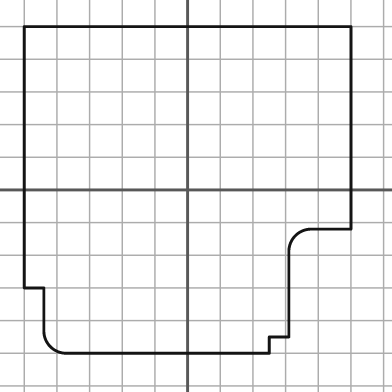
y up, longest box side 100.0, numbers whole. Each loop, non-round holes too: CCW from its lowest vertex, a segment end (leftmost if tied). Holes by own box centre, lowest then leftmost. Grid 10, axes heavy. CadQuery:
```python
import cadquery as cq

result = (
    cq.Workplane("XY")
    .moveTo(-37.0, -50.0)
    .lineTo(25.0, -50.0)
    .lineTo(25.0, -45.0)
    .lineTo(31.0, -45.0)
    .lineTo(31.0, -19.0)
    .threePointArc((33.0, -14.0), (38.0, -12.0))
    .lineTo(50.0, -12.0)
    .lineTo(50.0, 50.0)
    .lineTo(-50.0, 50.0)
    .lineTo(-50.0, -30.0)
    .lineTo(-44.0, -30.0)
    .lineTo(-44.0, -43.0)
    .threePointArc((-42.0, -48.0), (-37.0, -50.0))
    .close()
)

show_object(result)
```